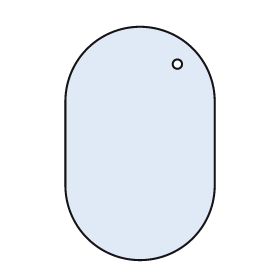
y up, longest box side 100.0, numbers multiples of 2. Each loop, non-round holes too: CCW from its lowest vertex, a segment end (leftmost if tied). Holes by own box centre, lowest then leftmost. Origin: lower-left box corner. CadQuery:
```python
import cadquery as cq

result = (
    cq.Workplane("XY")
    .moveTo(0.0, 32.0)
    .threePointArc((32.0, 0.0), (64.0, 32.0))
    .lineTo(64.0, 68.0)
    .threePointArc((32.0, 100.0), (0.0, 68.0))
    .close()
    .moveTo(48.0, 84.0)
    .circle(2.0)
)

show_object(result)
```